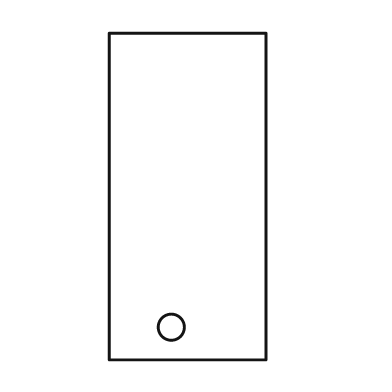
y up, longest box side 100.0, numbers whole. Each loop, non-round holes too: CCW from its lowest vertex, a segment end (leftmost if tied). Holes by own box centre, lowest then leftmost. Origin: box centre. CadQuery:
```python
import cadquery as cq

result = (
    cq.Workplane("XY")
    .moveTo(-24.0, -50.0)
    .lineTo(24.0, -50.0)
    .lineTo(24.0, 50.0)
    .lineTo(-24.0, 50.0)
    .close()
    .moveTo(-5.0, -40.0)
    .circle(4.0)
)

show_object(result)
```